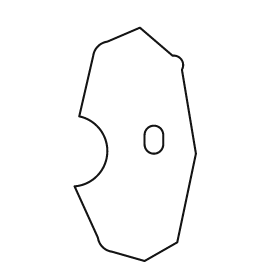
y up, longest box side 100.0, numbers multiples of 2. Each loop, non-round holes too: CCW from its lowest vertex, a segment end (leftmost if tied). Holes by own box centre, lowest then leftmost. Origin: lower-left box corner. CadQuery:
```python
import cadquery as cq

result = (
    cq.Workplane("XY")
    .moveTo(30.0, 0.0)
    .lineTo(44.0, 8.0)
    .lineTo(52.0, 46.0)
    .lineTo(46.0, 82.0)
    .threePointArc((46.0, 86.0), (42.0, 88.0))
    .lineTo(28.0, 100.0)
    .lineTo(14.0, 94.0)
    .threePointArc((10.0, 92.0), (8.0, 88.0))
    .lineTo(2.0, 62.0)
    .threePointArc((14.0, 46.0), (0.0, 32.0))
    .lineTo(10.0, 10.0)
    .threePointArc((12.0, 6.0), (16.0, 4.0))
    .close()
    .moveTo(30.0, 50.0)
    .threePointArc((34.0, 46.0), (38.0, 50.0))
    .lineTo(38.0, 54.0)
    .threePointArc((34.0, 58.0), (30.0, 54.0))
    .close()
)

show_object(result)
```